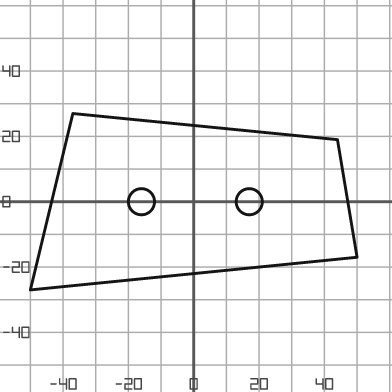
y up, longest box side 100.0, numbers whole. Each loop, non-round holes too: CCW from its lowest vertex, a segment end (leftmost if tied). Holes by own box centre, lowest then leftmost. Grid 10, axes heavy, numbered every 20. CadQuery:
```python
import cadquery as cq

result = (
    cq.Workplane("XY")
    .moveTo(-50.0, -27.0)
    .lineTo(50.0, -17.0)
    .lineTo(44.0, 19.0)
    .lineTo(-37.0, 27.0)
    .close()
    .moveTo(-16.0, 0.0)
    .circle(4.0)
    .moveTo(17.0, 0.0)
    .circle(4.0)
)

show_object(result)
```